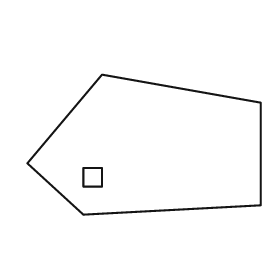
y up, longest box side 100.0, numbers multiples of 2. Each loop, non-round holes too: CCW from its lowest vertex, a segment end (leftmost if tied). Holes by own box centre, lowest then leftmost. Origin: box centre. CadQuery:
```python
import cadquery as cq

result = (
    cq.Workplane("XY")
    .moveTo(-26.0, -30.0)
    .lineTo(50.0, -26.0)
    .lineTo(50.0, 18.0)
    .lineTo(-18.0, 30.0)
    .lineTo(-50.0, -8.0)
    .close()
    .moveTo(-26.0, -18.0)
    .lineTo(-18.0, -18.0)
    .lineTo(-18.0, -10.0)
    .lineTo(-26.0, -10.0)
    .close()
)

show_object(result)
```